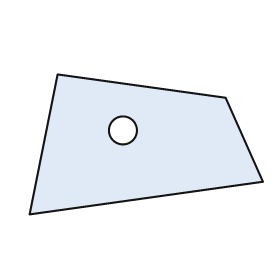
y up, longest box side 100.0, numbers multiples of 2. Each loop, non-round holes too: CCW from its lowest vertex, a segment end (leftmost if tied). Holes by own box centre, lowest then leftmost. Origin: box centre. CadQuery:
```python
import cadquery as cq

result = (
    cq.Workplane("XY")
    .moveTo(-50.0, -30.0)
    .lineTo(50.0, -16.0)
    .lineTo(34.0, 20.0)
    .lineTo(-38.0, 30.0)
    .close()
    .moveTo(-10.0, 6.0)
    .circle(6.0)
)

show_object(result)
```